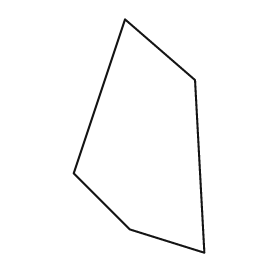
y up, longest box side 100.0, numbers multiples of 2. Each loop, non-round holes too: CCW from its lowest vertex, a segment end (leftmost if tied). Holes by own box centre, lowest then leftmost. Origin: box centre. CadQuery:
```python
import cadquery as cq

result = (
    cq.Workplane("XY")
    .moveTo(28.0, -50.0)
    .lineTo(24.0, 24.0)
    .lineTo(-6.0, 50.0)
    .lineTo(-28.0, -16.0)
    .lineTo(-4.0, -40.0)
    .close()
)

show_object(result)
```